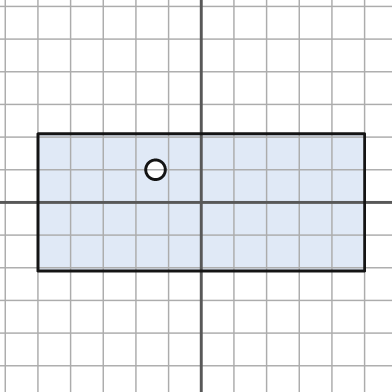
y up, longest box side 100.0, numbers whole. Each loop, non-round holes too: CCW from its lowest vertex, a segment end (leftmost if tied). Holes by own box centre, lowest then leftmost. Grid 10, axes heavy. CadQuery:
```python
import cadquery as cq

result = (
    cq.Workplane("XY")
    .moveTo(-50.0, -21.0)
    .lineTo(50.0, -21.0)
    .lineTo(50.0, 21.0)
    .lineTo(-50.0, 21.0)
    .close()
    .moveTo(-14.0, 10.0)
    .circle(3.0)
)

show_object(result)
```